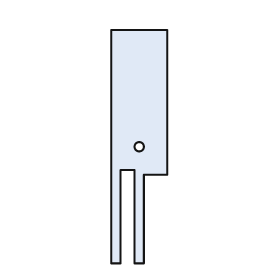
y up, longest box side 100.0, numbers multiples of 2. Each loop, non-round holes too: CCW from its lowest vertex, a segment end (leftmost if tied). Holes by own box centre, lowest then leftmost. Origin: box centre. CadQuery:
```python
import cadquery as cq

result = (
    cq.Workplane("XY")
    .moveTo(-12.0, -50.0)
    .lineTo(-8.0, -50.0)
    .lineTo(-8.0, -10.0)
    .lineTo(-2.0, -10.0)
    .lineTo(-2.0, -50.0)
    .lineTo(2.0, -50.0)
    .lineTo(2.0, -12.0)
    .lineTo(12.0, -12.0)
    .lineTo(12.0, 50.0)
    .lineTo(-12.0, 50.0)
    .close()
    .moveTo(0.0, 0.0)
    .circle(2.0)
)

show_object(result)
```